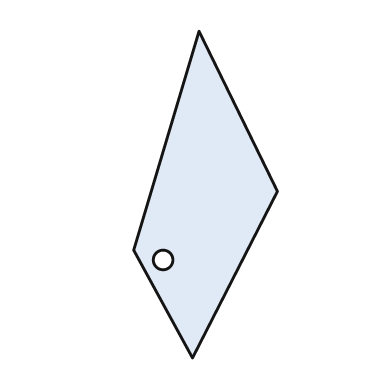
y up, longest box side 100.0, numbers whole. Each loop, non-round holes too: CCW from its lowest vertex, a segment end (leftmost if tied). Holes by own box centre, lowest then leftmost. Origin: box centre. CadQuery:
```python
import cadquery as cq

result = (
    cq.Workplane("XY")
    .moveTo(-4.0, -50.0)
    .lineTo(22.0, 1.0)
    .lineTo(-2.0, 50.0)
    .lineTo(-22.0, -17.0)
    .close()
    .moveTo(-13.0, -20.0)
    .circle(3.0)
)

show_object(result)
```